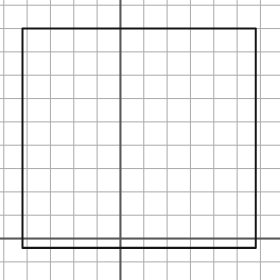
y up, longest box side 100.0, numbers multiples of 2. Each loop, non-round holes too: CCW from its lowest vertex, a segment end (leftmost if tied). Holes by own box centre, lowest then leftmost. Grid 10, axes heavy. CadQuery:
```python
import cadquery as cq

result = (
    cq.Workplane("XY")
    .moveTo(-42.0, -4.0)
    .lineTo(58.0, -4.0)
    .lineTo(58.0, 90.0)
    .lineTo(-42.0, 90.0)
    .close()
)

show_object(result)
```